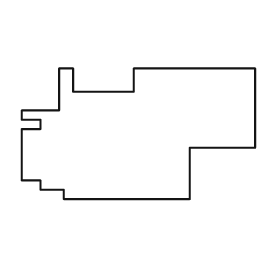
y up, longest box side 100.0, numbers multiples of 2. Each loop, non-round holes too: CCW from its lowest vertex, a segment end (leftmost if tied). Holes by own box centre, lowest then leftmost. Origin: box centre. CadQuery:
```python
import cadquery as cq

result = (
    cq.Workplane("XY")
    .moveTo(-32.0, -28.0)
    .lineTo(22.0, -28.0)
    .lineTo(22.0, -6.0)
    .lineTo(50.0, -6.0)
    .lineTo(50.0, 28.0)
    .lineTo(-2.0, 28.0)
    .lineTo(-2.0, 18.0)
    .lineTo(-28.0, 18.0)
    .lineTo(-28.0, 28.0)
    .lineTo(-34.0, 28.0)
    .lineTo(-34.0, 10.0)
    .lineTo(-50.0, 10.0)
    .lineTo(-50.0, 6.0)
    .lineTo(-42.0, 6.0)
    .lineTo(-42.0, 2.0)
    .lineTo(-50.0, 2.0)
    .lineTo(-50.0, -20.0)
    .lineTo(-42.0, -20.0)
    .lineTo(-42.0, -24.0)
    .lineTo(-32.0, -24.0)
    .close()
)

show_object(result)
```